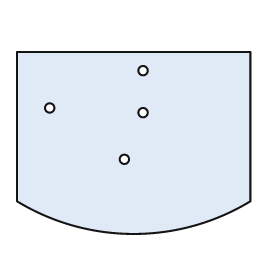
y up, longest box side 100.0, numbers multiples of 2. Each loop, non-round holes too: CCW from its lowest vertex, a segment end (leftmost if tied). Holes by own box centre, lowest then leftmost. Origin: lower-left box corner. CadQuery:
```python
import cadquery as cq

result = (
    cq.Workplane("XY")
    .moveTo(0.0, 14.0)
    .threePointArc((50.0, 0.0), (100.0, 14.0))
    .lineTo(100.0, 78.0)
    .lineTo(0.0, 78.0)
    .close()
    .moveTo(46.0, 32.0)
    .circle(2.0)
    .moveTo(54.0, 52.0)
    .circle(2.0)
    .moveTo(14.0, 54.0)
    .circle(2.0)
    .moveTo(54.0, 70.0)
    .circle(2.0)
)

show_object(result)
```